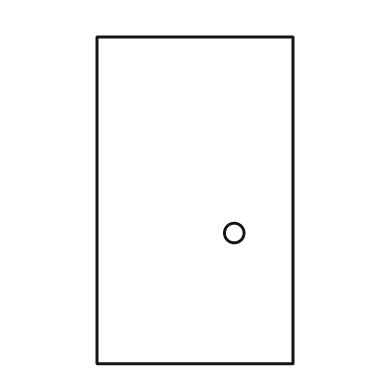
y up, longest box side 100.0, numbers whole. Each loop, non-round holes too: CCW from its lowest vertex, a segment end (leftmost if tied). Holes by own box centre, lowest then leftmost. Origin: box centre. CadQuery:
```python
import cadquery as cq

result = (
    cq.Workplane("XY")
    .moveTo(-30.0, -50.0)
    .lineTo(30.0, -50.0)
    .lineTo(30.0, 50.0)
    .lineTo(-30.0, 50.0)
    .close()
    .moveTo(12.0, -10.0)
    .circle(3.0)
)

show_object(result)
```